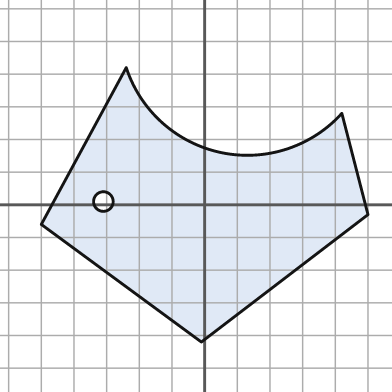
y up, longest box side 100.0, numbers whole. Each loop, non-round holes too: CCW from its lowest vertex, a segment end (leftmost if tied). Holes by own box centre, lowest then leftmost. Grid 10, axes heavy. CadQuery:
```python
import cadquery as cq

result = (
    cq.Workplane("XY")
    .moveTo(-1.0, -42.0)
    .lineTo(50.0, -3.0)
    .lineTo(42.0, 28.0)
    .threePointArc((5.0, 16.0), (-24.0, 42.0))
    .lineTo(-50.0, -6.0)
    .close()
    .moveTo(-31.0, 1.0)
    .circle(3.0)
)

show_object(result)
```